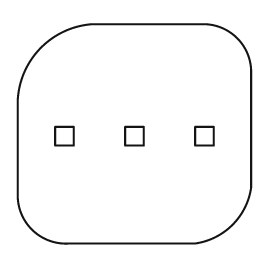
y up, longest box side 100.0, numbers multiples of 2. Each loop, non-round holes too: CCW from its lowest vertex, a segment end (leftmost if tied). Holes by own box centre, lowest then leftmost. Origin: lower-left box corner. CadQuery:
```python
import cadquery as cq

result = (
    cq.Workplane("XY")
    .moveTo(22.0, 0.0)
    .lineTo(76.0, 0.0)
    .threePointArc((92.0, 8.0), (100.0, 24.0))
    .lineTo(100.0, 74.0)
    .threePointArc((94.0, 88.0), (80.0, 94.0))
    .lineTo(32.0, 94.0)
    .threePointArc((10.0, 84.0), (0.0, 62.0))
    .lineTo(0.0, 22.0)
    .threePointArc((6.0, 6.0), (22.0, 0.0))
    .close()
    .moveTo(16.0, 42.0)
    .lineTo(24.0, 42.0)
    .lineTo(24.0, 50.0)
    .lineTo(16.0, 50.0)
    .close()
    .moveTo(46.0, 42.0)
    .lineTo(54.0, 42.0)
    .lineTo(54.0, 50.0)
    .lineTo(46.0, 50.0)
    .close()
    .moveTo(76.0, 42.0)
    .lineTo(84.0, 42.0)
    .lineTo(84.0, 50.0)
    .lineTo(76.0, 50.0)
    .close()
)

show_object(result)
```